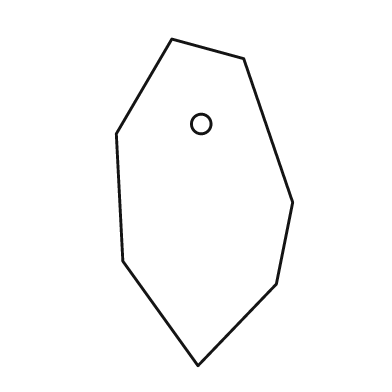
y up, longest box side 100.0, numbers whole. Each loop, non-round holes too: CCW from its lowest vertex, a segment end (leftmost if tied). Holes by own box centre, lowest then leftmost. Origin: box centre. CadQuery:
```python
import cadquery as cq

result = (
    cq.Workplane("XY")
    .moveTo(-2.0, -50.0)
    .lineTo(22.0, -25.0)
    .lineTo(27.0, 0.0)
    .lineTo(12.0, 44.0)
    .lineTo(-10.0, 50.0)
    .lineTo(-27.0, 21.0)
    .lineTo(-25.0, -18.0)
    .close()
    .moveTo(-1.0, 24.0)
    .circle(3.0)
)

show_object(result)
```